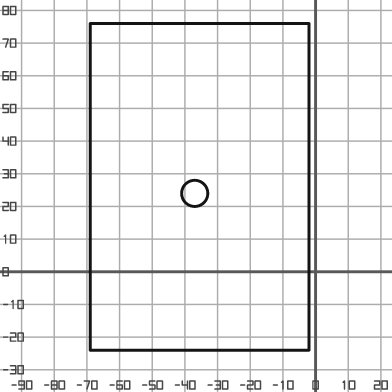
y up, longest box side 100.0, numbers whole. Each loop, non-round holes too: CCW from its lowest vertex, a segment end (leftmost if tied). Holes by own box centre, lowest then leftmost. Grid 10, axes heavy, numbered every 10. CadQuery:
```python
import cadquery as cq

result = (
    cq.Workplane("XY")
    .moveTo(-69.0, -24.0)
    .lineTo(-2.0, -24.0)
    .lineTo(-2.0, 76.0)
    .lineTo(-69.0, 76.0)
    .close()
    .moveTo(-37.0, 24.0)
    .circle(4.0)
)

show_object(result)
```